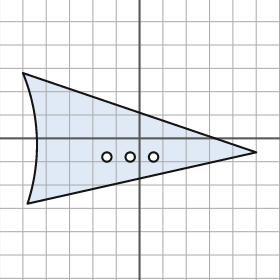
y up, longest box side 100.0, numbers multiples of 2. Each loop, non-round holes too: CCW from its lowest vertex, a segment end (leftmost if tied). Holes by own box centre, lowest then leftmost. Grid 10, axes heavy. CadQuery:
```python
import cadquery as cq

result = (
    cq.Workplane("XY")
    .moveTo(-48.0, -28.0)
    .lineTo(50.0, -6.0)
    .lineTo(-50.0, 28.0)
    .threePointArc((-44.0, 0.0), (-48.0, -28.0))
    .close()
    .moveTo(-14.0, -8.0)
    .circle(2.0)
    .moveTo(-4.0, -8.0)
    .circle(2.0)
    .moveTo(6.0, -8.0)
    .circle(2.0)
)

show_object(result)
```